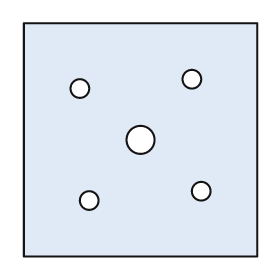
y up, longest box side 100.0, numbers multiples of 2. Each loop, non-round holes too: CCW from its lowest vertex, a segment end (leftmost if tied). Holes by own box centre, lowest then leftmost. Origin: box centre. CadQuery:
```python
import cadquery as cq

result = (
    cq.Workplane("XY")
    .moveTo(-50.0, -50.0)
    .lineTo(50.0, -50.0)
    .lineTo(50.0, 50.0)
    .lineTo(-50.0, 50.0)
    .close()
    .moveTo(-22.0, -26.0)
    .circle(4.0)
    .moveTo(26.0, -22.0)
    .circle(4.0)
    .moveTo(0.0, 0.0)
    .circle(6.0)
    .moveTo(-26.0, 22.0)
    .circle(4.0)
    .moveTo(22.0, 26.0)
    .circle(4.0)
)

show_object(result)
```